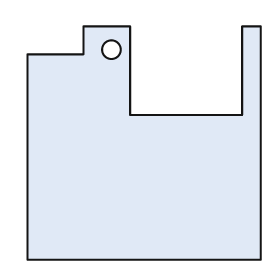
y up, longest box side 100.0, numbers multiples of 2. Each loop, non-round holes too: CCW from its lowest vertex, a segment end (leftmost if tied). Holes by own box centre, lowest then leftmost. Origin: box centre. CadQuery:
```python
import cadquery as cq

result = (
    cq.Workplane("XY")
    .moveTo(-50.0, -50.0)
    .lineTo(50.0, -50.0)
    .lineTo(50.0, 50.0)
    .lineTo(42.0, 50.0)
    .lineTo(42.0, 12.0)
    .lineTo(-6.0, 12.0)
    .lineTo(-6.0, 50.0)
    .lineTo(-26.0, 50.0)
    .lineTo(-26.0, 38.0)
    .lineTo(-50.0, 38.0)
    .close()
    .moveTo(-14.0, 40.0)
    .circle(4.0)
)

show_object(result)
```